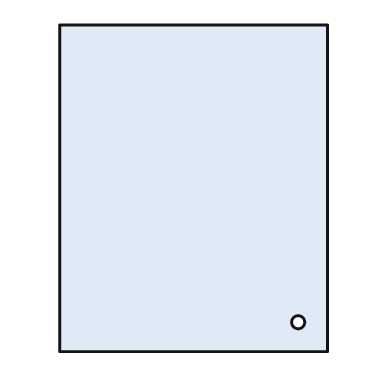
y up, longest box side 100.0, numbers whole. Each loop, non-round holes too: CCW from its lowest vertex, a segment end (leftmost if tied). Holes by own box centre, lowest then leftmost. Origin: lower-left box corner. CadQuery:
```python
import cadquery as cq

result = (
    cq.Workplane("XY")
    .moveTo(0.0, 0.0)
    .lineTo(82.0, 0.0)
    .lineTo(82.0, 100.0)
    .lineTo(0.0, 100.0)
    .close()
    .moveTo(73.0, 9.0)
    .circle(2.0)
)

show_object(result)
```